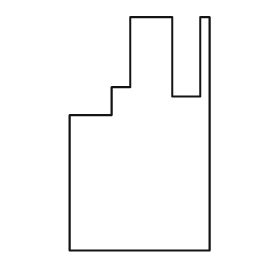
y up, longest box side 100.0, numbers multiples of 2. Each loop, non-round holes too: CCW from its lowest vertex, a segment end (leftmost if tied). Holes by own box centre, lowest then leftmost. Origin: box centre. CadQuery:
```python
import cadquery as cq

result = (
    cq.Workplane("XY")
    .moveTo(-30.0, -50.0)
    .lineTo(30.0, -50.0)
    .lineTo(30.0, 50.0)
    .lineTo(26.0, 50.0)
    .lineTo(26.0, 16.0)
    .lineTo(14.0, 16.0)
    .lineTo(14.0, 50.0)
    .lineTo(-4.0, 50.0)
    .lineTo(-4.0, 20.0)
    .lineTo(-12.0, 20.0)
    .lineTo(-12.0, 8.0)
    .lineTo(-30.0, 8.0)
    .close()
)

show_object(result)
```